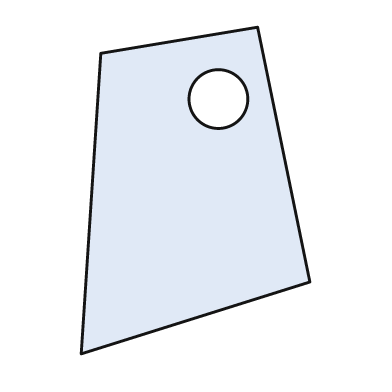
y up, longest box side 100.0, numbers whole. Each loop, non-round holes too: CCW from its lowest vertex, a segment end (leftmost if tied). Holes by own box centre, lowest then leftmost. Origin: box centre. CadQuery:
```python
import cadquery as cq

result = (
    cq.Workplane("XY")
    .moveTo(-35.0, -50.0)
    .lineTo(35.0, -28.0)
    .lineTo(19.0, 50.0)
    .lineTo(-29.0, 42.0)
    .close()
    .moveTo(7.0, 28.0)
    .circle(9.0)
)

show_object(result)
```